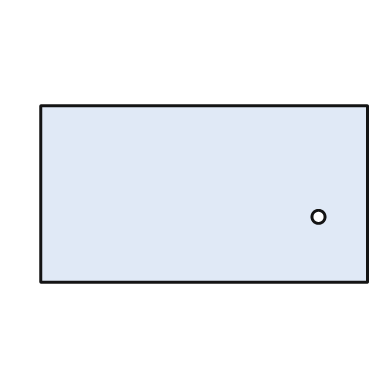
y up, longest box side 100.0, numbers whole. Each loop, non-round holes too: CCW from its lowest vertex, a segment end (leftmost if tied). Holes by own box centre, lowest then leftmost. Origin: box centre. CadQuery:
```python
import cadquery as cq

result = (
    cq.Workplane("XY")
    .moveTo(-50.0, -27.0)
    .lineTo(50.0, -27.0)
    .lineTo(50.0, 27.0)
    .lineTo(-50.0, 27.0)
    .close()
    .moveTo(35.0, -7.0)
    .circle(2.0)
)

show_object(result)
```